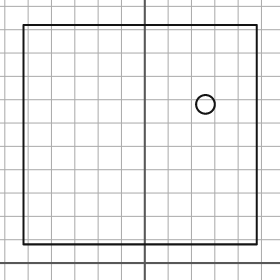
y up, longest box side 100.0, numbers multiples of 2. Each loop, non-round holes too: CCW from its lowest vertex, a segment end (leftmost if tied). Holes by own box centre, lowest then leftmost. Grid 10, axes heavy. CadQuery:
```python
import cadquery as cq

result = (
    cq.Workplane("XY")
    .moveTo(-52.0, 8.0)
    .lineTo(48.0, 8.0)
    .lineTo(48.0, 102.0)
    .lineTo(-52.0, 102.0)
    .close()
    .moveTo(26.0, 68.0)
    .circle(4.0)
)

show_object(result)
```